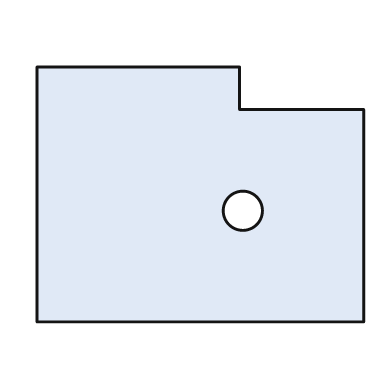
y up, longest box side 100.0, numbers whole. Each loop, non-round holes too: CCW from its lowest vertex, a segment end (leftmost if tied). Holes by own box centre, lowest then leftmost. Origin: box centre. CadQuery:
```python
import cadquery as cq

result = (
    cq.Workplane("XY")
    .moveTo(-50.0, -39.0)
    .lineTo(50.0, -39.0)
    .lineTo(50.0, 26.0)
    .lineTo(12.0, 26.0)
    .lineTo(12.0, 39.0)
    .lineTo(-50.0, 39.0)
    .close()
    .moveTo(13.0, -5.0)
    .circle(6.0)
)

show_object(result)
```